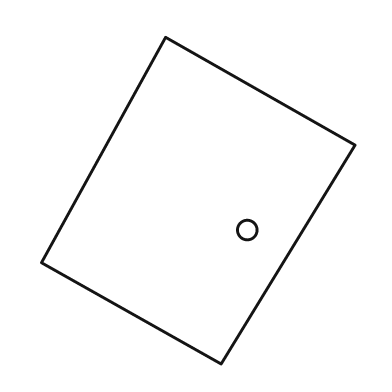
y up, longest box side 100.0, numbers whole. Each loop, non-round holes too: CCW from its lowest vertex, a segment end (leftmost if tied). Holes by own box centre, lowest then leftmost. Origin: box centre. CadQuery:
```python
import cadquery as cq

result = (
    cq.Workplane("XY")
    .moveTo(7.0, -50.0)
    .lineTo(48.0, 17.0)
    .lineTo(-10.0, 50.0)
    .lineTo(-48.0, -19.0)
    .close()
    .moveTo(15.0, -9.0)
    .circle(3.0)
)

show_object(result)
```